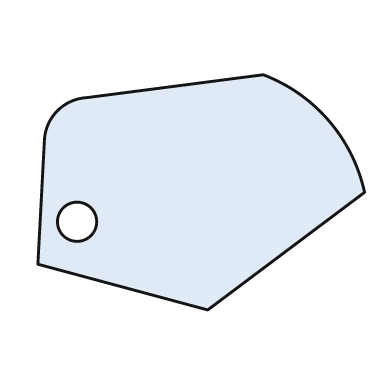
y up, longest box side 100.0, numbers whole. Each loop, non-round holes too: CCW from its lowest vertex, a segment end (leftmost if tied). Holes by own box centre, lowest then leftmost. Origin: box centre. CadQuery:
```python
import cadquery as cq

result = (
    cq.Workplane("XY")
    .moveTo(2.0, -36.0)
    .lineTo(50.0, 0.0)
    .threePointArc((39.0, 22.0), (19.0, 36.0))
    .lineTo(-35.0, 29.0)
    .threePointArc((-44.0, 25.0), (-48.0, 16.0))
    .lineTo(-50.0, -22.0)
    .close()
    .moveTo(-38.0, -9.0)
    .circle(6.0)
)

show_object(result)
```